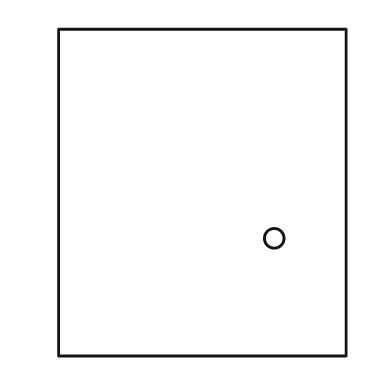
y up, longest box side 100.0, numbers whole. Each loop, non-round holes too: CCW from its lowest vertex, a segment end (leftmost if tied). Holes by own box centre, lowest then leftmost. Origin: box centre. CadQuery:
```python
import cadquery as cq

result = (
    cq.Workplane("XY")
    .moveTo(-44.0, -50.0)
    .lineTo(44.0, -50.0)
    .lineTo(44.0, 50.0)
    .lineTo(-44.0, 50.0)
    .close()
    .moveTo(22.0, -14.0)
    .circle(3.0)
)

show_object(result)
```